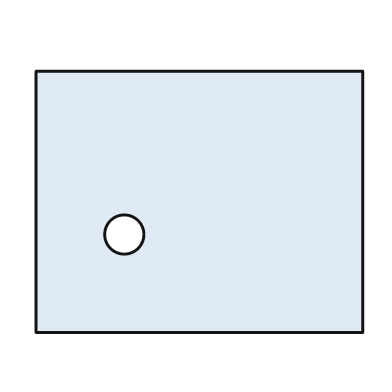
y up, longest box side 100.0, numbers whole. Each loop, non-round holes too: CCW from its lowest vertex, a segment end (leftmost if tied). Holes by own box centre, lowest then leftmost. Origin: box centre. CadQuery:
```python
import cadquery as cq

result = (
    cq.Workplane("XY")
    .moveTo(-50.0, -40.0)
    .lineTo(50.0, -40.0)
    .lineTo(50.0, 40.0)
    .lineTo(-50.0, 40.0)
    .close()
    .moveTo(-23.0, -10.0)
    .circle(6.0)
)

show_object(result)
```